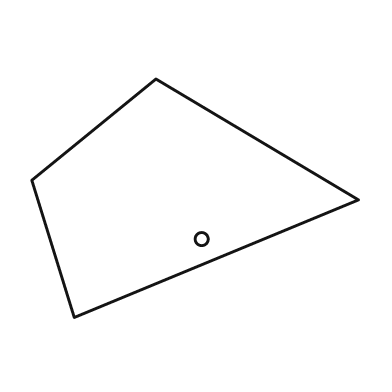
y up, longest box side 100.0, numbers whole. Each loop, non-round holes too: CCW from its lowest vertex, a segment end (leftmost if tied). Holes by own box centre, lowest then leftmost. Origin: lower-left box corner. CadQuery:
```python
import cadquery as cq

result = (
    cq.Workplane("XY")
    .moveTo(13.0, 0.0)
    .lineTo(100.0, 36.0)
    .lineTo(38.0, 73.0)
    .lineTo(0.0, 42.0)
    .close()
    .moveTo(52.0, 24.0)
    .circle(2.0)
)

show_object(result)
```